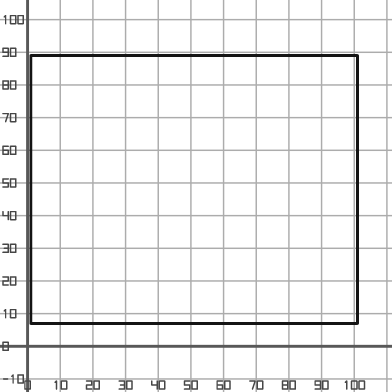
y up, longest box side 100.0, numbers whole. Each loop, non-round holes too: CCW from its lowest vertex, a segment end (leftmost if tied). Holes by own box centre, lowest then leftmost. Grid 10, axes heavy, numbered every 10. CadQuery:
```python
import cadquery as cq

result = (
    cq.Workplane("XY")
    .moveTo(1.0, 7.0)
    .lineTo(101.0, 7.0)
    .lineTo(101.0, 89.0)
    .lineTo(1.0, 89.0)
    .close()
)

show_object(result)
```